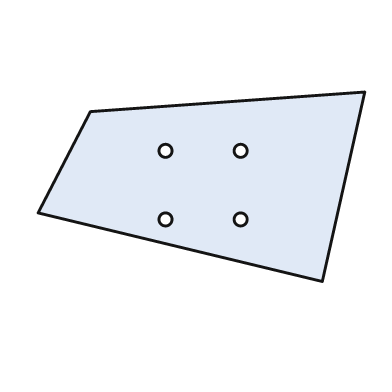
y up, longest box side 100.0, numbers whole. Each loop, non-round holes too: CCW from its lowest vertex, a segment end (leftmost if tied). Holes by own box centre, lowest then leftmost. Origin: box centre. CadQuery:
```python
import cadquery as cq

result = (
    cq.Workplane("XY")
    .moveTo(37.0, -29.0)
    .lineTo(50.0, 29.0)
    .lineTo(-34.0, 23.0)
    .lineTo(-50.0, -8.0)
    .close()
    .moveTo(-11.0, -10.0)
    .circle(2.0)
    .moveTo(12.0, -10.0)
    .circle(2.0)
    .moveTo(-11.0, 11.0)
    .circle(2.0)
    .moveTo(12.0, 11.0)
    .circle(2.0)
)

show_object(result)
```